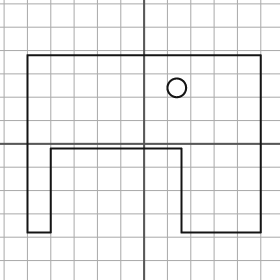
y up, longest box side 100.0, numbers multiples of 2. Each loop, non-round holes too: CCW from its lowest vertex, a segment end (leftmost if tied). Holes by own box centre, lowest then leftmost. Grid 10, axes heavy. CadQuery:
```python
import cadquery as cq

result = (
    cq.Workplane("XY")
    .moveTo(-50.0, -38.0)
    .lineTo(-40.0, -38.0)
    .lineTo(-40.0, -2.0)
    .lineTo(16.0, -2.0)
    .lineTo(16.0, -38.0)
    .lineTo(50.0, -38.0)
    .lineTo(50.0, 38.0)
    .lineTo(-50.0, 38.0)
    .close()
    .moveTo(14.0, 24.0)
    .circle(4.0)
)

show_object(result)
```